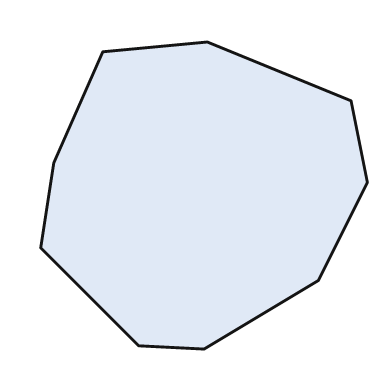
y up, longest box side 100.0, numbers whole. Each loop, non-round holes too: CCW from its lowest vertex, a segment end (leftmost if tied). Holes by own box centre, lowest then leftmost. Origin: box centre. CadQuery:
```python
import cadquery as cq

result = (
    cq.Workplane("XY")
    .moveTo(0.0, -47.0)
    .lineTo(35.0, -26.0)
    .lineTo(50.0, 4.0)
    .lineTo(45.0, 29.0)
    .lineTo(1.0, 47.0)
    .lineTo(-31.0, 44.0)
    .lineTo(-46.0, 10.0)
    .lineTo(-50.0, -16.0)
    .lineTo(-20.0, -46.0)
    .close()
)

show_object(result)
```